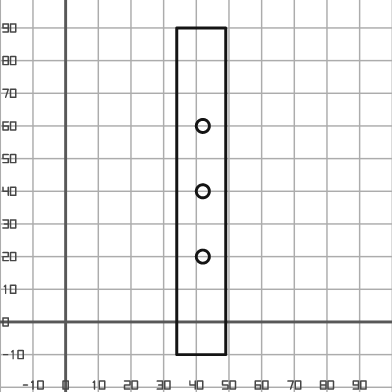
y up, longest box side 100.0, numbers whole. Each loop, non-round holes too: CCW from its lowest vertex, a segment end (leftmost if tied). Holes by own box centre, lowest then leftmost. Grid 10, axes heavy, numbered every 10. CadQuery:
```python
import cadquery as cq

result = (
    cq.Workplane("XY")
    .moveTo(34.0, -10.0)
    .lineTo(49.0, -10.0)
    .lineTo(49.0, 90.0)
    .lineTo(34.0, 90.0)
    .close()
    .moveTo(42.0, 20.0)
    .circle(2.0)
    .moveTo(42.0, 40.0)
    .circle(2.0)
    .moveTo(42.0, 60.0)
    .circle(2.0)
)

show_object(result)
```